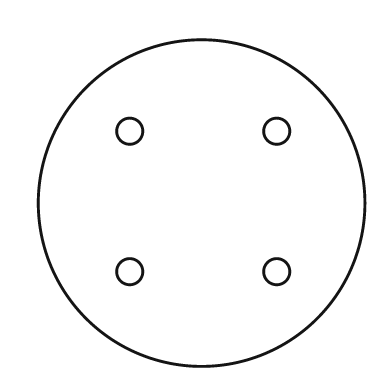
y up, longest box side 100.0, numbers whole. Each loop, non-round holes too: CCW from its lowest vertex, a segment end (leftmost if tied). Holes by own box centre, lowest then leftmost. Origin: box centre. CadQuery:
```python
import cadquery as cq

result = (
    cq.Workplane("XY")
    .moveTo(0.0, 0.0)
    .circle(50.0)
    .moveTo(-22.0, -21.0)
    .circle(4.0)
    .moveTo(23.0, -21.0)
    .circle(4.0)
    .moveTo(-22.0, 22.0)
    .circle(4.0)
    .moveTo(23.0, 22.0)
    .circle(4.0)
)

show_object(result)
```